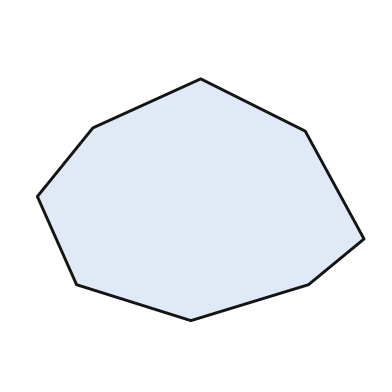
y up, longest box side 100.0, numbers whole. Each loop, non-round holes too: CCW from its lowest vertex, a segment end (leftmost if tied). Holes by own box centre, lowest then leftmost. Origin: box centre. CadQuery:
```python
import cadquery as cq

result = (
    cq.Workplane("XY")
    .moveTo(-3.0, -37.0)
    .lineTo(33.0, -26.0)
    .lineTo(50.0, -12.0)
    .lineTo(32.0, 21.0)
    .lineTo(0.0, 37.0)
    .lineTo(-33.0, 22.0)
    .lineTo(-50.0, 1.0)
    .lineTo(-38.0, -26.0)
    .close()
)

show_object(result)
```